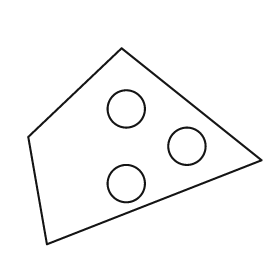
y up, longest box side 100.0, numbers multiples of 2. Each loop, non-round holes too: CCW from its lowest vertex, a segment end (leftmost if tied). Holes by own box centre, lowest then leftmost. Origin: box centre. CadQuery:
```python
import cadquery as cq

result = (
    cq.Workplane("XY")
    .moveTo(-42.0, -42.0)
    .lineTo(50.0, -6.0)
    .lineTo(-10.0, 42.0)
    .lineTo(-50.0, 4.0)
    .close()
    .moveTo(-8.0, -16.0)
    .circle(8.0)
    .moveTo(18.0, 0.0)
    .circle(8.0)
    .moveTo(-8.0, 16.0)
    .circle(8.0)
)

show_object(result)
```